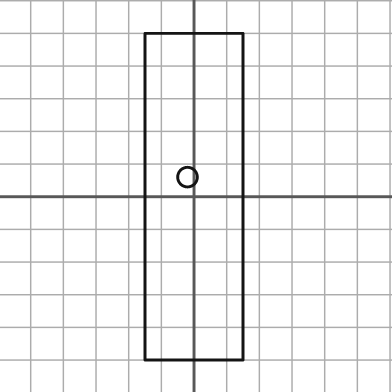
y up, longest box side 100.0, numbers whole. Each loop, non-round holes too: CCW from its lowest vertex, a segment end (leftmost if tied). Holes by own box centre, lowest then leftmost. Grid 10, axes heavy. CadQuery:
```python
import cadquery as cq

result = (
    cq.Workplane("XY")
    .moveTo(-15.0, -50.0)
    .lineTo(15.0, -50.0)
    .lineTo(15.0, 50.0)
    .lineTo(-15.0, 50.0)
    .close()
    .moveTo(-2.0, 6.0)
    .circle(3.0)
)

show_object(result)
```